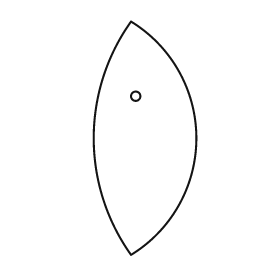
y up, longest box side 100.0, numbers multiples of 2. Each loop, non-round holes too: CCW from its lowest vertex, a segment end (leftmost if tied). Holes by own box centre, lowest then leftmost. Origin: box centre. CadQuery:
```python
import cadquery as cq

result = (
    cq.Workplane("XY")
    .moveTo(-6.0, -50.0)
    .threePointArc((22.0, 0.0), (-6.0, 50.0))
    .threePointArc((-22.0, 0.0), (-6.0, -50.0))
    .close()
    .moveTo(-4.0, 18.0)
    .circle(2.0)
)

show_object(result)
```